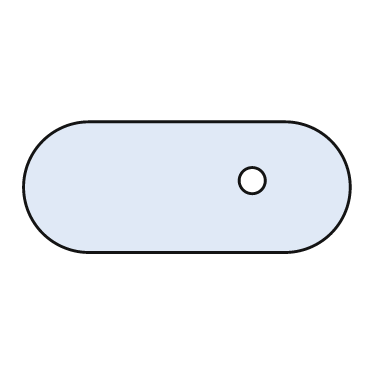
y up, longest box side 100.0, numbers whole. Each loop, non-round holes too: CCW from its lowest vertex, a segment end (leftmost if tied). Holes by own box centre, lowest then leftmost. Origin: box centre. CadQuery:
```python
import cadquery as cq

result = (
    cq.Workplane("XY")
    .moveTo(-30.0, -20.0)
    .lineTo(30.0, -20.0)
    .threePointArc((50.0, 0.0), (30.0, 20.0))
    .lineTo(-30.0, 20.0)
    .threePointArc((-50.0, 0.0), (-30.0, -20.0))
    .close()
    .moveTo(20.0, 2.0)
    .circle(4.0)
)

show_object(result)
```